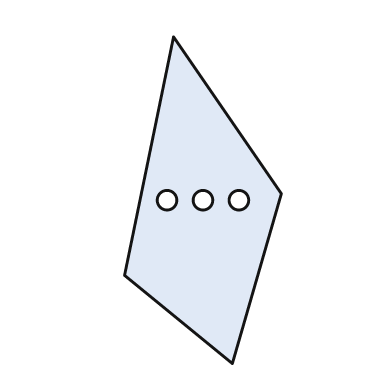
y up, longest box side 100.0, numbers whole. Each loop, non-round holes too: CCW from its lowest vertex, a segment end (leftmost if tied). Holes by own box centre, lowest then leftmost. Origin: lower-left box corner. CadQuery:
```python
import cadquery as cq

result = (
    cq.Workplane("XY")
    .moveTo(33.0, 0.0)
    .lineTo(48.0, 52.0)
    .lineTo(15.0, 100.0)
    .lineTo(0.0, 27.0)
    .close()
    .moveTo(13.0, 50.0)
    .circle(3.0)
    .moveTo(24.0, 50.0)
    .circle(3.0)
    .moveTo(35.0, 50.0)
    .circle(3.0)
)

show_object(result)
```